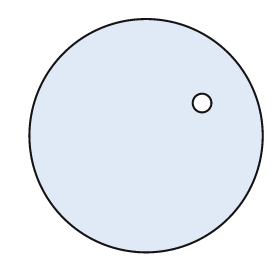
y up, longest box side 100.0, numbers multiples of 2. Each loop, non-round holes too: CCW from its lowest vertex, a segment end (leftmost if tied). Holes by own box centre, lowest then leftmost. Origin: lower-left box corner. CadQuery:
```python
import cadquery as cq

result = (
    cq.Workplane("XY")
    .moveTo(50.0, 50.0)
    .circle(50.0)
    .moveTo(74.0, 64.0)
    .circle(4.0)
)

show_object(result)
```